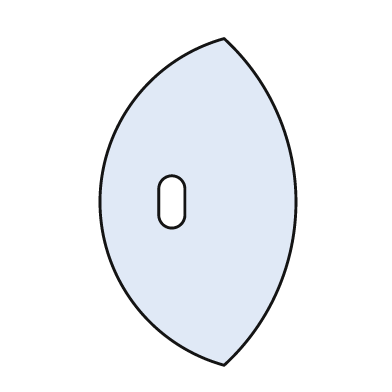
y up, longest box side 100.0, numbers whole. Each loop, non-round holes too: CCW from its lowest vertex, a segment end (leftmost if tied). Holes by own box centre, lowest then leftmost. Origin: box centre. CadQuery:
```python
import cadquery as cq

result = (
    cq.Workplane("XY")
    .moveTo(8.0, -50.0)
    .threePointArc((30.0, 0.0), (8.0, 50.0))
    .threePointArc((-30.0, 0.0), (8.0, -50.0))
    .close()
    .moveTo(-12.0, -4.0)
    .threePointArc((-8.0, -8.0), (-4.0, -4.0))
    .lineTo(-4.0, 4.0)
    .threePointArc((-8.0, 8.0), (-12.0, 4.0))
    .close()
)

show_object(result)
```